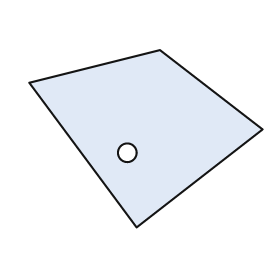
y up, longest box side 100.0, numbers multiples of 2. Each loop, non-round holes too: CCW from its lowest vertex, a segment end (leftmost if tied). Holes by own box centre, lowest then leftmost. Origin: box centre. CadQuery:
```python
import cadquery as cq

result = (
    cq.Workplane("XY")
    .moveTo(-4.0, -38.0)
    .lineTo(50.0, 4.0)
    .lineTo(6.0, 38.0)
    .lineTo(-50.0, 24.0)
    .close()
    .moveTo(-8.0, -6.0)
    .circle(4.0)
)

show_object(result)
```